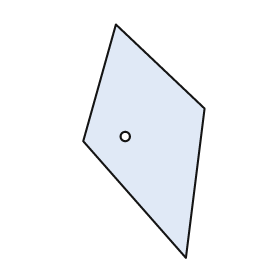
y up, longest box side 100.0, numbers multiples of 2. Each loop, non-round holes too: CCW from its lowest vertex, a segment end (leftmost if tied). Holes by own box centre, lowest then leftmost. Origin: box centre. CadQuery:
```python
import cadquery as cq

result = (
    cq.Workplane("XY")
    .moveTo(18.0, -50.0)
    .lineTo(26.0, 14.0)
    .lineTo(-12.0, 50.0)
    .lineTo(-26.0, 0.0)
    .close()
    .moveTo(-8.0, 2.0)
    .circle(2.0)
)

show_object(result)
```